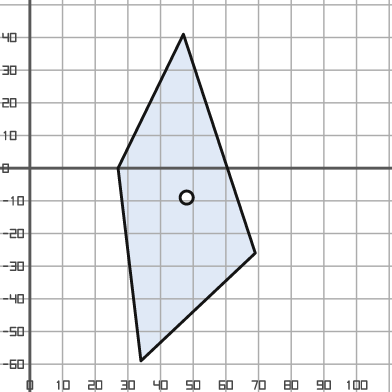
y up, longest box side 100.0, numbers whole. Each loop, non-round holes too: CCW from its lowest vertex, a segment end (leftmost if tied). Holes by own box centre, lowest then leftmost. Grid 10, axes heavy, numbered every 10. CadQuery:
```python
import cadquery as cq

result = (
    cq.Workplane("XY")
    .moveTo(34.0, -59.0)
    .lineTo(69.0, -26.0)
    .lineTo(47.0, 41.0)
    .lineTo(27.0, 0.0)
    .close()
    .moveTo(48.0, -9.0)
    .circle(2.0)
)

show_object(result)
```